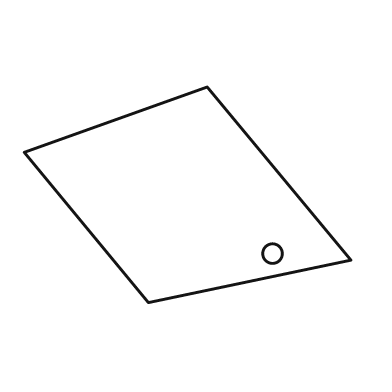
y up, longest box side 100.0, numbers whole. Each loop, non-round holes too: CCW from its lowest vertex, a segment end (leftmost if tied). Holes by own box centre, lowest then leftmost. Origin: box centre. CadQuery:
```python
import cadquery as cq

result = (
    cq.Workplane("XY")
    .moveTo(-12.0, -33.0)
    .lineTo(50.0, -20.0)
    .lineTo(6.0, 33.0)
    .lineTo(-50.0, 13.0)
    .close()
    .moveTo(26.0, -18.0)
    .circle(3.0)
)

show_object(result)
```